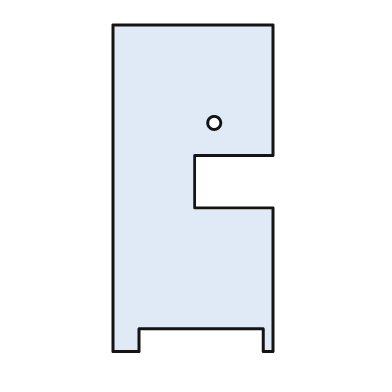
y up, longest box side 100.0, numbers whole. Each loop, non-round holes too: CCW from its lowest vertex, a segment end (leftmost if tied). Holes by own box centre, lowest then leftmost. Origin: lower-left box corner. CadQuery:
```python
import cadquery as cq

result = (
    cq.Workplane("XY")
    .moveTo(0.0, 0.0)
    .lineTo(8.0, 0.0)
    .lineTo(8.0, 7.0)
    .lineTo(46.0, 7.0)
    .lineTo(46.0, 0.0)
    .lineTo(49.0, 0.0)
    .lineTo(49.0, 44.0)
    .lineTo(25.0, 44.0)
    .lineTo(25.0, 60.0)
    .lineTo(49.0, 60.0)
    .lineTo(49.0, 100.0)
    .lineTo(0.0, 100.0)
    .close()
    .moveTo(31.0, 70.0)
    .circle(2.0)
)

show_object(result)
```